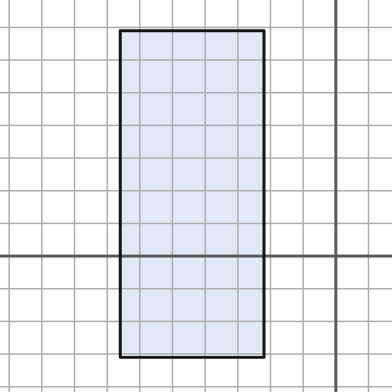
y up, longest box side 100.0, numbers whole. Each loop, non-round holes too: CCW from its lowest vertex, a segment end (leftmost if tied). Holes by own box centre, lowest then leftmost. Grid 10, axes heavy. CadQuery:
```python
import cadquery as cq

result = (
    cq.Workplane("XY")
    .moveTo(-66.0, -31.0)
    .lineTo(-22.0, -31.0)
    .lineTo(-22.0, 69.0)
    .lineTo(-66.0, 69.0)
    .close()
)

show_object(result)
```